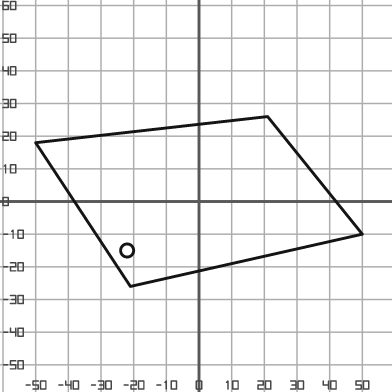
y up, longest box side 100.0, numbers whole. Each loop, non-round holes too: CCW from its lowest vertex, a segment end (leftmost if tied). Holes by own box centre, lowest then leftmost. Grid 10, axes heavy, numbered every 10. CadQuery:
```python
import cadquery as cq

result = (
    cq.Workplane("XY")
    .moveTo(-21.0, -26.0)
    .lineTo(50.0, -10.0)
    .lineTo(21.0, 26.0)
    .lineTo(-50.0, 18.0)
    .close()
    .moveTo(-22.0, -15.0)
    .circle(2.0)
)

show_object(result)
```